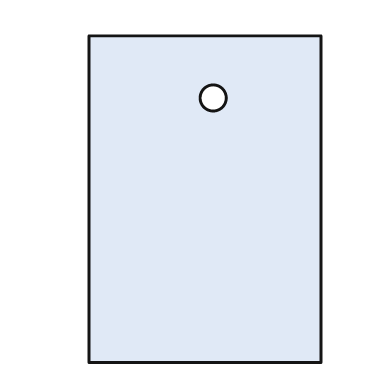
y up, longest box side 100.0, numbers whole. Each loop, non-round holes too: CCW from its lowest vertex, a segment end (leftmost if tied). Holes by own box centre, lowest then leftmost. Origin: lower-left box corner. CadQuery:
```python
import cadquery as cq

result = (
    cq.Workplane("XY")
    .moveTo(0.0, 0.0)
    .lineTo(71.0, 0.0)
    .lineTo(71.0, 100.0)
    .lineTo(0.0, 100.0)
    .close()
    .moveTo(38.0, 81.0)
    .circle(4.0)
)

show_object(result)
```